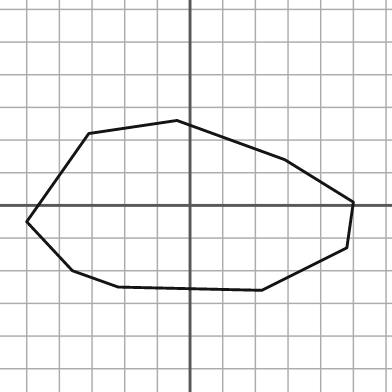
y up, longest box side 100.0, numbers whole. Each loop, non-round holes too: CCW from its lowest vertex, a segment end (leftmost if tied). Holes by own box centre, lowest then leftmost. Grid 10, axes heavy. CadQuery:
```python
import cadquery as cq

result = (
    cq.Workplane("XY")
    .moveTo(22.0, -26.0)
    .lineTo(48.0, -13.0)
    .lineTo(50.0, 1.0)
    .lineTo(29.0, 14.0)
    .lineTo(-4.0, 26.0)
    .lineTo(-31.0, 22.0)
    .lineTo(-50.0, -5.0)
    .lineTo(-36.0, -20.0)
    .lineTo(-22.0, -25.0)
    .close()
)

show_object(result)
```